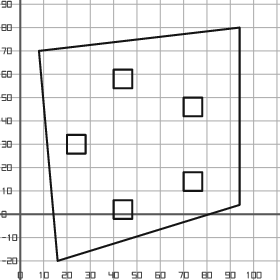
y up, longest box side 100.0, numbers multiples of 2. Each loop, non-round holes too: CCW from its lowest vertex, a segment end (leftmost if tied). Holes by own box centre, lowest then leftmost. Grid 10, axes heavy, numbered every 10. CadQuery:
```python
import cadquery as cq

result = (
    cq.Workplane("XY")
    .moveTo(16.0, -20.0)
    .lineTo(94.0, 4.0)
    .lineTo(94.0, 80.0)
    .lineTo(8.0, 70.0)
    .close()
    .moveTo(40.0, -2.0)
    .lineTo(48.0, -2.0)
    .lineTo(48.0, 6.0)
    .lineTo(40.0, 6.0)
    .close()
    .moveTo(70.0, 10.0)
    .lineTo(78.0, 10.0)
    .lineTo(78.0, 18.0)
    .lineTo(70.0, 18.0)
    .close()
    .moveTo(20.0, 26.0)
    .lineTo(28.0, 26.0)
    .lineTo(28.0, 34.0)
    .lineTo(20.0, 34.0)
    .close()
    .moveTo(70.0, 42.0)
    .lineTo(78.0, 42.0)
    .lineTo(78.0, 50.0)
    .lineTo(70.0, 50.0)
    .close()
    .moveTo(40.0, 54.0)
    .lineTo(48.0, 54.0)
    .lineTo(48.0, 62.0)
    .lineTo(40.0, 62.0)
    .close()
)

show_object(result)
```